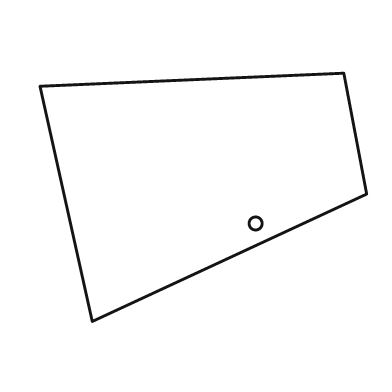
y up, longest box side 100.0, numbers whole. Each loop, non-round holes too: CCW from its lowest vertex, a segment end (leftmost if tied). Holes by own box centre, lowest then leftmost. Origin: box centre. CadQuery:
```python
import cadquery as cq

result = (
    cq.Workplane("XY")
    .moveTo(-34.0, -38.0)
    .lineTo(50.0, 1.0)
    .lineTo(43.0, 38.0)
    .lineTo(-50.0, 34.0)
    .close()
    .moveTo(16.0, -8.0)
    .circle(2.0)
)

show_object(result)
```